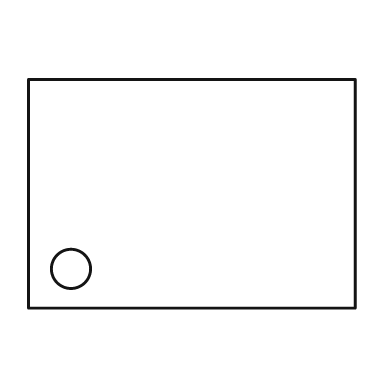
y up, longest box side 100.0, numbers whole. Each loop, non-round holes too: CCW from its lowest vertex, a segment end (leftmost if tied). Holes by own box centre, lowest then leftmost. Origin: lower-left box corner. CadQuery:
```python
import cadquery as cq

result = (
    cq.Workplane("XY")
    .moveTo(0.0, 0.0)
    .lineTo(100.0, 0.0)
    .lineTo(100.0, 70.0)
    .lineTo(0.0, 70.0)
    .close()
    .moveTo(13.0, 12.0)
    .circle(6.0)
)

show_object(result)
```